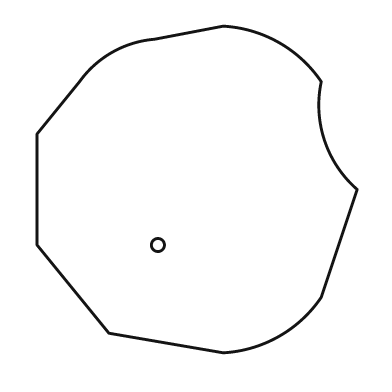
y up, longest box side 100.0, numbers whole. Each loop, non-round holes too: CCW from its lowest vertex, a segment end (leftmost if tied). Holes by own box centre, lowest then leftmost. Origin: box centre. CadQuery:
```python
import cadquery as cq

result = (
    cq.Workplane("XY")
    .moveTo(8.0, -50.0)
    .threePointArc((25.0, -45.0), (38.0, -33.0))
    .lineTo(49.0, 0.0)
    .threePointArc((39.0, 15.0), (38.0, 33.0))
    .threePointArc((25.0, 45.0), (8.0, 50.0))
    .lineTo(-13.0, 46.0)
    .threePointArc((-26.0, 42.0), (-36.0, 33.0))
    .lineTo(-49.0, 17.0)
    .lineTo(-49.0, -17.0)
    .lineTo(-27.0, -44.0)
    .close()
    .moveTo(-12.0, -17.0)
    .circle(2.0)
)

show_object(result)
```